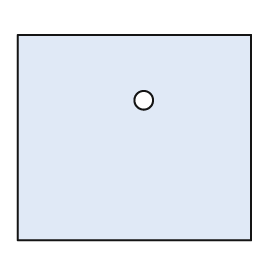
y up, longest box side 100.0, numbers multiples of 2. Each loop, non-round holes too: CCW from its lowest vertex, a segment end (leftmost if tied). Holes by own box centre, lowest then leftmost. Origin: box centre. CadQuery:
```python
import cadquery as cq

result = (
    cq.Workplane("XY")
    .moveTo(-50.0, -44.0)
    .lineTo(50.0, -44.0)
    .lineTo(50.0, 44.0)
    .lineTo(-50.0, 44.0)
    .close()
    .moveTo(4.0, 16.0)
    .circle(4.0)
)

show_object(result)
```